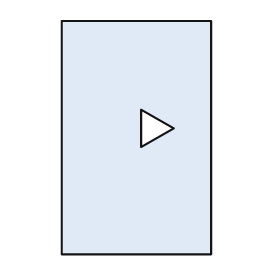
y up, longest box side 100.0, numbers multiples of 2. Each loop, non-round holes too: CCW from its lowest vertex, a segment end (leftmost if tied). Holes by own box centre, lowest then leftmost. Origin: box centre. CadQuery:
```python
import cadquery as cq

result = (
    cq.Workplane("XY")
    .moveTo(-32.0, -50.0)
    .lineTo(32.0, -50.0)
    .lineTo(32.0, 50.0)
    .lineTo(-32.0, 50.0)
    .close()
    .moveTo(2.0, -4.0)
    .lineTo(16.0, 4.0)
    .lineTo(2.0, 12.0)
    .close()
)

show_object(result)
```